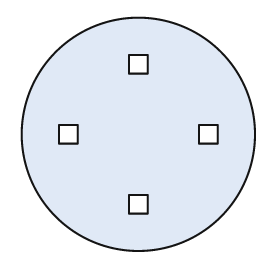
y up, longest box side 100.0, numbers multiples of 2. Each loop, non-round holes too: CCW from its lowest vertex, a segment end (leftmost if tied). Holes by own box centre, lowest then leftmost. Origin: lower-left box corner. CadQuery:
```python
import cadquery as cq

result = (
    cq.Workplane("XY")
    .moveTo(50.0, 50.0)
    .circle(50.0)
    .moveTo(46.0, 16.0)
    .lineTo(54.0, 16.0)
    .lineTo(54.0, 24.0)
    .lineTo(46.0, 24.0)
    .close()
    .moveTo(16.0, 46.0)
    .lineTo(24.0, 46.0)
    .lineTo(24.0, 54.0)
    .lineTo(16.0, 54.0)
    .close()
    .moveTo(76.0, 46.0)
    .lineTo(84.0, 46.0)
    .lineTo(84.0, 54.0)
    .lineTo(76.0, 54.0)
    .close()
    .moveTo(46.0, 76.0)
    .lineTo(54.0, 76.0)
    .lineTo(54.0, 84.0)
    .lineTo(46.0, 84.0)
    .close()
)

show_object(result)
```